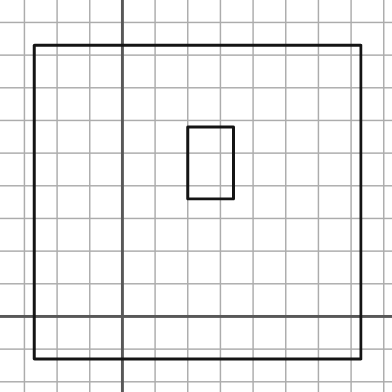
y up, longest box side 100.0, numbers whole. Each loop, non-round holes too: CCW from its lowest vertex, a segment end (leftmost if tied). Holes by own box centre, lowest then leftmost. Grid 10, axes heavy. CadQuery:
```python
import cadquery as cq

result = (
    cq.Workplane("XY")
    .moveTo(-27.0, -13.0)
    .lineTo(73.0, -13.0)
    .lineTo(73.0, 83.0)
    .lineTo(-27.0, 83.0)
    .close()
    .moveTo(20.0, 36.0)
    .lineTo(34.0, 36.0)
    .lineTo(34.0, 58.0)
    .lineTo(20.0, 58.0)
    .close()
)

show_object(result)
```